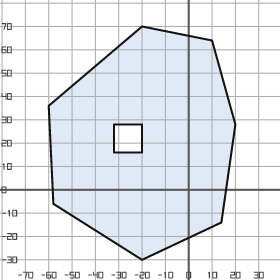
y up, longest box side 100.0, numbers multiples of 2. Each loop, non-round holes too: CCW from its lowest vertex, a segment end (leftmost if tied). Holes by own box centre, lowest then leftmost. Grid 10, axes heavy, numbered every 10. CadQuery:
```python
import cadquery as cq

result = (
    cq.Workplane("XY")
    .moveTo(-20.0, -30.0)
    .lineTo(14.0, -14.0)
    .lineTo(20.0, 28.0)
    .lineTo(10.0, 64.0)
    .lineTo(-20.0, 70.0)
    .lineTo(-60.0, 36.0)
    .lineTo(-58.0, -6.0)
    .close()
    .moveTo(-32.0, 16.0)
    .lineTo(-20.0, 16.0)
    .lineTo(-20.0, 28.0)
    .lineTo(-32.0, 28.0)
    .close()
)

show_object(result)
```